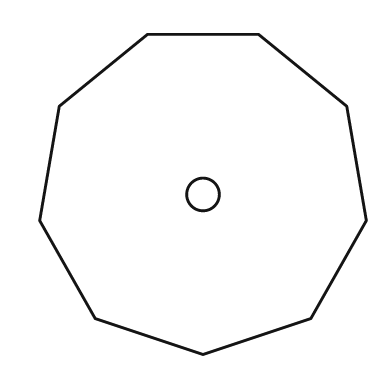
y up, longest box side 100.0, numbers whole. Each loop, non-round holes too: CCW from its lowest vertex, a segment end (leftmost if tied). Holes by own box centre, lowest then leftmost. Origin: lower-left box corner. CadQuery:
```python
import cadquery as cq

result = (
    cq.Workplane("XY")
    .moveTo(50.0, 0.0)
    .lineTo(83.0, 11.0)
    .lineTo(100.0, 41.0)
    .lineTo(94.0, 76.0)
    .lineTo(67.0, 98.0)
    .lineTo(33.0, 98.0)
    .lineTo(6.0, 76.0)
    .lineTo(0.0, 41.0)
    .lineTo(17.0, 11.0)
    .close()
    .moveTo(50.0, 49.0)
    .circle(5.0)
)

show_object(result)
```